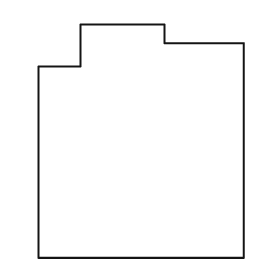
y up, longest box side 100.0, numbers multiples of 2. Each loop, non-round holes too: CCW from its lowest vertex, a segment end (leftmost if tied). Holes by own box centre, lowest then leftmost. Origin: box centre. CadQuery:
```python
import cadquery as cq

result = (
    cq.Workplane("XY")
    .moveTo(-44.0, -50.0)
    .lineTo(44.0, -50.0)
    .lineTo(44.0, 42.0)
    .lineTo(10.0, 42.0)
    .lineTo(10.0, 50.0)
    .lineTo(-26.0, 50.0)
    .lineTo(-26.0, 32.0)
    .lineTo(-44.0, 32.0)
    .close()
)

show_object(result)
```